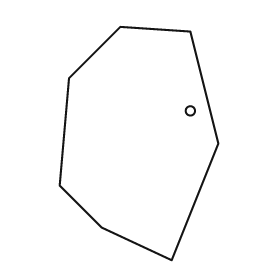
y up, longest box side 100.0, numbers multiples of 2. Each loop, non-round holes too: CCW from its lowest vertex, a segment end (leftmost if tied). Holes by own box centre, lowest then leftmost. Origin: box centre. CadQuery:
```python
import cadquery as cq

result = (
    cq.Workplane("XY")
    .moveTo(14.0, -50.0)
    .lineTo(34.0, 0.0)
    .lineTo(22.0, 48.0)
    .lineTo(-8.0, 50.0)
    .lineTo(-30.0, 28.0)
    .lineTo(-34.0, -18.0)
    .lineTo(-16.0, -36.0)
    .close()
    .moveTo(22.0, 14.0)
    .circle(2.0)
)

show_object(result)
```